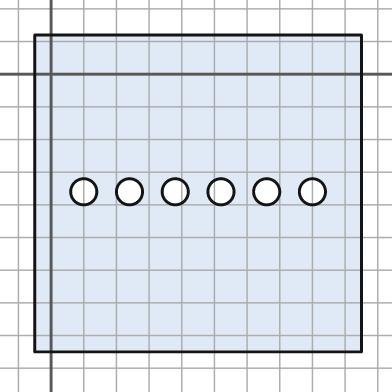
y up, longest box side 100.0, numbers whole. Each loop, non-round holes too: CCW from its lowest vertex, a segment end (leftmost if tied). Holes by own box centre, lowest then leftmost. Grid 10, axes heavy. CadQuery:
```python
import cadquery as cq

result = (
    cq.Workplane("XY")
    .moveTo(-5.0, -85.0)
    .lineTo(95.0, -85.0)
    .lineTo(95.0, 12.0)
    .lineTo(-5.0, 12.0)
    .close()
    .moveTo(10.0, -36.0)
    .circle(4.0)
    .moveTo(24.0, -36.0)
    .circle(4.0)
    .moveTo(38.0, -36.0)
    .circle(4.0)
    .moveTo(52.0, -36.0)
    .circle(4.0)
    .moveTo(66.0, -36.0)
    .circle(4.0)
    .moveTo(80.0, -36.0)
    .circle(4.0)
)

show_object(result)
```